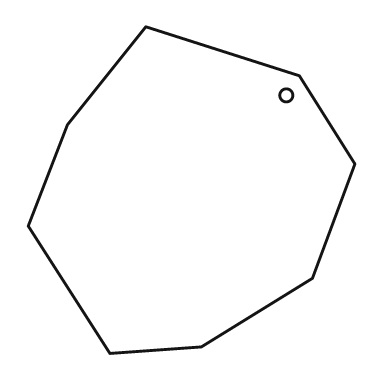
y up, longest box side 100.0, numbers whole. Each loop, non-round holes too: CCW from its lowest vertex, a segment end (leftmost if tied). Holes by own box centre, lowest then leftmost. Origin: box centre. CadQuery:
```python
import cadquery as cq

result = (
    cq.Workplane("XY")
    .moveTo(-25.0, -50.0)
    .lineTo(3.0, -48.0)
    .lineTo(37.0, -27.0)
    .lineTo(50.0, 8.0)
    .lineTo(33.0, 35.0)
    .lineTo(-14.0, 50.0)
    .lineTo(-38.0, 20.0)
    .lineTo(-50.0, -11.0)
    .close()
    .moveTo(29.0, 29.0)
    .circle(2.0)
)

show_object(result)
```